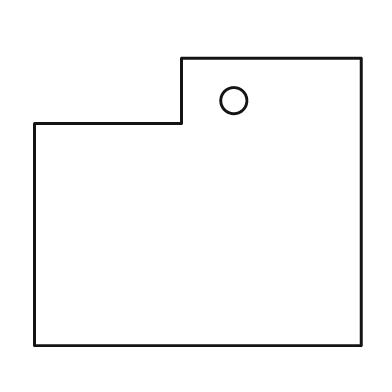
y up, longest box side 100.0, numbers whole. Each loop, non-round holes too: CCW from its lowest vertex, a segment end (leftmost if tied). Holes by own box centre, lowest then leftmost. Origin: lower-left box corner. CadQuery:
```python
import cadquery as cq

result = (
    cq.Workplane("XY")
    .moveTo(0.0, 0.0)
    .lineTo(100.0, 0.0)
    .lineTo(100.0, 88.0)
    .lineTo(45.0, 88.0)
    .lineTo(45.0, 68.0)
    .lineTo(0.0, 68.0)
    .close()
    .moveTo(61.0, 75.0)
    .circle(4.0)
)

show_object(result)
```